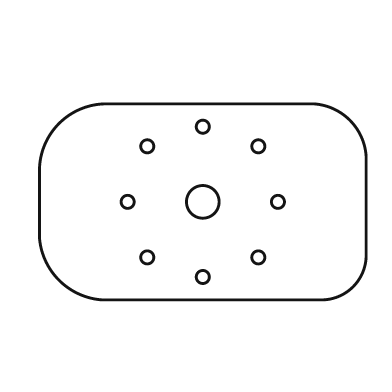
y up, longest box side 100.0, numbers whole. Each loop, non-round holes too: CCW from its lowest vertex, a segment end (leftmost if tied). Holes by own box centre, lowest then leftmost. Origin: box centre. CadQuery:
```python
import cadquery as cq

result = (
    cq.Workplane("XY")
    .moveTo(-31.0, -30.0)
    .lineTo(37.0, -30.0)
    .threePointArc((46.0, -26.0), (50.0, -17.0))
    .lineTo(50.0, 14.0)
    .threePointArc((45.0, 25.0), (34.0, 30.0))
    .lineTo(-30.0, 30.0)
    .threePointArc((-44.0, 24.0), (-50.0, 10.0))
    .lineTo(-50.0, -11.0)
    .threePointArc((-44.0, -24.0), (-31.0, -30.0))
    .close()
    .moveTo(0.0, -23.0)
    .circle(2.0)
    .moveTo(-17.0, -17.0)
    .circle(2.0)
    .moveTo(17.0, -17.0)
    .circle(2.0)
    .moveTo(-23.0, 0.0)
    .circle(2.0)
    .moveTo(0.0, 0.0)
    .circle(5.0)
    .moveTo(23.0, 0.0)
    .circle(2.0)
    .moveTo(-17.0, 17.0)
    .circle(2.0)
    .moveTo(17.0, 17.0)
    .circle(2.0)
    .moveTo(0.0, 23.0)
    .circle(2.0)
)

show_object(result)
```